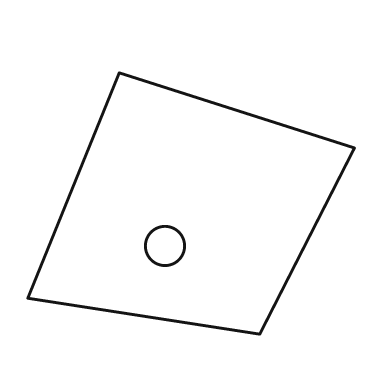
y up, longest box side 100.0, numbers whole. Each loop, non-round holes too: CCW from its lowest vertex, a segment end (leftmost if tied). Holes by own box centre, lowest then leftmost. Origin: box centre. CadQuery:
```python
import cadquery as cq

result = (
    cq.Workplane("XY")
    .moveTo(21.0, -40.0)
    .lineTo(50.0, 17.0)
    .lineTo(-22.0, 40.0)
    .lineTo(-50.0, -29.0)
    .close()
    .moveTo(-8.0, -13.0)
    .circle(6.0)
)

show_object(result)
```